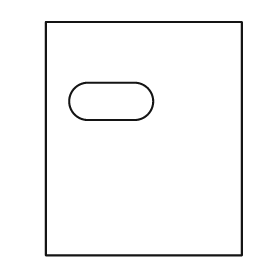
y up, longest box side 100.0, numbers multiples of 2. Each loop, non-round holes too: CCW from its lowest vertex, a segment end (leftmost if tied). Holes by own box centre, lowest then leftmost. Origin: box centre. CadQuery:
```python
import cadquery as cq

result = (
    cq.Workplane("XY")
    .moveTo(-42.0, -50.0)
    .lineTo(42.0, -50.0)
    .lineTo(42.0, 50.0)
    .lineTo(-42.0, 50.0)
    .close()
    .moveTo(-24.0, 8.0)
    .lineTo(-4.0, 8.0)
    .threePointArc((4.0, 16.0), (-4.0, 24.0))
    .lineTo(-24.0, 24.0)
    .threePointArc((-32.0, 16.0), (-24.0, 8.0))
    .close()
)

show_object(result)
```